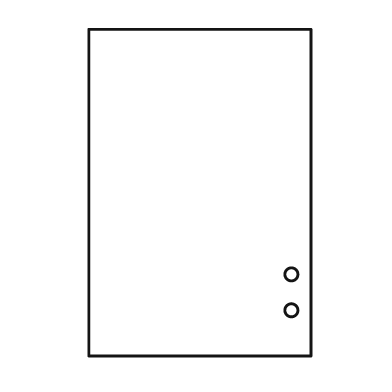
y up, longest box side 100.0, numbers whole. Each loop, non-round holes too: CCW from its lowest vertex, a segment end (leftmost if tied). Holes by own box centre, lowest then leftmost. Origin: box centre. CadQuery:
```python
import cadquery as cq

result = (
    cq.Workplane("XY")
    .moveTo(-34.0, -50.0)
    .lineTo(34.0, -50.0)
    .lineTo(34.0, 50.0)
    .lineTo(-34.0, 50.0)
    .close()
    .moveTo(28.0, -36.0)
    .circle(2.0)
    .moveTo(28.0, -25.0)
    .circle(2.0)
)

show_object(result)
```